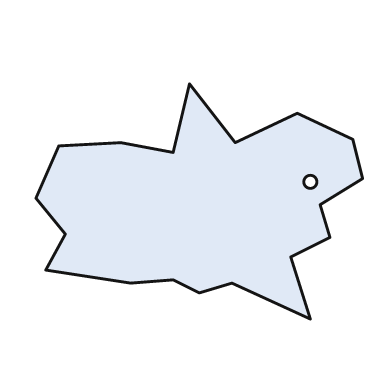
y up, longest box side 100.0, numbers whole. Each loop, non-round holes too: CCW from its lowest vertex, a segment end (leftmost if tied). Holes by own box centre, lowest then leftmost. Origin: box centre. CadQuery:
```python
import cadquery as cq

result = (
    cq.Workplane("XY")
    .moveTo(34.0, -36.0)
    .lineTo(28.0, -17.0)
    .lineTo(40.0, -11.0)
    .lineTo(37.0, -1.0)
    .lineTo(50.0, 7.0)
    .lineTo(47.0, 19.0)
    .lineTo(30.0, 27.0)
    .lineTo(11.0, 18.0)
    .lineTo(-3.0, 36.0)
    .lineTo(-8.0, 15.0)
    .lineTo(-24.0, 18.0)
    .lineTo(-43.0, 17.0)
    .lineTo(-50.0, 1.0)
    .lineTo(-41.0, -10.0)
    .lineTo(-47.0, -21.0)
    .lineTo(-21.0, -25.0)
    .lineTo(-8.0, -24.0)
    .lineTo(0.0, -28.0)
    .lineTo(10.0, -25.0)
    .close()
    .moveTo(34.0, 6.0)
    .circle(2.0)
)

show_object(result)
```